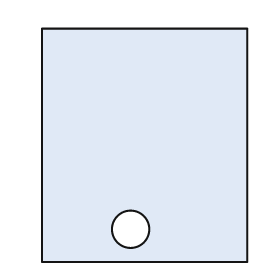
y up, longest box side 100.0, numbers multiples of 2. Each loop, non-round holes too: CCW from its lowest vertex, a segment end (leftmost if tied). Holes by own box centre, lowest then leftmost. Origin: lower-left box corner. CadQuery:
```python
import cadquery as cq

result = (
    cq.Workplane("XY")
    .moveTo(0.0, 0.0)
    .lineTo(88.0, 0.0)
    .lineTo(88.0, 100.0)
    .lineTo(0.0, 100.0)
    .close()
    .moveTo(38.0, 14.0)
    .circle(8.0)
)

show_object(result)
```